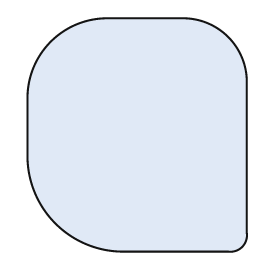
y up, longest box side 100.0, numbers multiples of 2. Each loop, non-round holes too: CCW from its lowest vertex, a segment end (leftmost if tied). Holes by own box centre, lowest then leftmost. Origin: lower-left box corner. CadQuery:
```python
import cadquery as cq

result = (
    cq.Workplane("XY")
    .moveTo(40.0, 0.0)
    .lineTo(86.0, 0.0)
    .threePointArc((92.0, 2.0), (94.0, 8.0))
    .lineTo(94.0, 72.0)
    .threePointArc((86.0, 92.0), (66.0, 100.0))
    .lineTo(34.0, 100.0)
    .threePointArc((10.0, 90.0), (0.0, 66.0))
    .lineTo(0.0, 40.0)
    .threePointArc((12.0, 12.0), (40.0, 0.0))
    .close()
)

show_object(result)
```